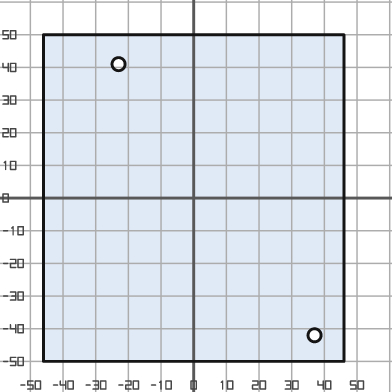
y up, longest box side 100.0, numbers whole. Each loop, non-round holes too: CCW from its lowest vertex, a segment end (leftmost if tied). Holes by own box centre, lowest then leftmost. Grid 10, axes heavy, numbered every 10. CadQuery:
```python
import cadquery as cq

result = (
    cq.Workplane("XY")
    .moveTo(-46.0, -50.0)
    .lineTo(46.0, -50.0)
    .lineTo(46.0, 50.0)
    .lineTo(-46.0, 50.0)
    .close()
    .moveTo(37.0, -42.0)
    .circle(2.0)
    .moveTo(-23.0, 41.0)
    .circle(2.0)
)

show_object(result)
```